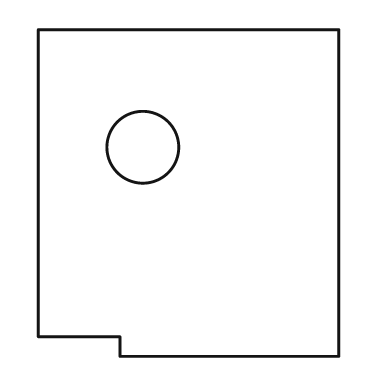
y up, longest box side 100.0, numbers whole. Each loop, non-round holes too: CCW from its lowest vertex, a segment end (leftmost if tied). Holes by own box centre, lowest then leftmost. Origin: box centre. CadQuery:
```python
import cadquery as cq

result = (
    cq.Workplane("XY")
    .moveTo(-21.0, -50.0)
    .lineTo(46.0, -50.0)
    .lineTo(46.0, 50.0)
    .lineTo(-46.0, 50.0)
    .lineTo(-46.0, -44.0)
    .lineTo(-21.0, -44.0)
    .close()
    .moveTo(-14.0, 14.0)
    .circle(11.0)
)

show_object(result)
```